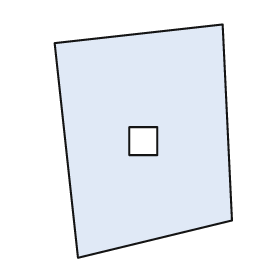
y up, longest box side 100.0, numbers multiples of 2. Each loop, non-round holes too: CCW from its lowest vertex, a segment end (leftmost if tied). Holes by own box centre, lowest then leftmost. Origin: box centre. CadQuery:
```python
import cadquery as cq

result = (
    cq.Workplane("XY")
    .moveTo(-28.0, -50.0)
    .lineTo(38.0, -34.0)
    .lineTo(34.0, 50.0)
    .lineTo(-38.0, 42.0)
    .close()
    .moveTo(-6.0, -6.0)
    .lineTo(6.0, -6.0)
    .lineTo(6.0, 6.0)
    .lineTo(-6.0, 6.0)
    .close()
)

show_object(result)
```